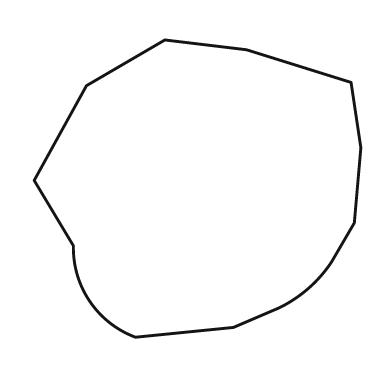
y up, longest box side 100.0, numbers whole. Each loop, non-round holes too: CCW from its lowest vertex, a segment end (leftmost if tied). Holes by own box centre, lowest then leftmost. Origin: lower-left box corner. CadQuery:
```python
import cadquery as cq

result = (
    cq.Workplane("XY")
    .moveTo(31.0, 0.0)
    .lineTo(61.0, 3.0)
    .lineTo(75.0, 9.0)
    .threePointArc((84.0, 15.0), (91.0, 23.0))
    .lineTo(98.0, 35.0)
    .lineTo(100.0, 58.0)
    .lineTo(97.0, 78.0)
    .lineTo(65.0, 88.0)
    .lineTo(40.0, 91.0)
    .lineTo(16.0, 77.0)
    .lineTo(0.0, 48.0)
    .lineTo(12.0, 28.0)
    .threePointArc((17.0, 11.0), (31.0, 0.0))
    .close()
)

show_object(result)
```